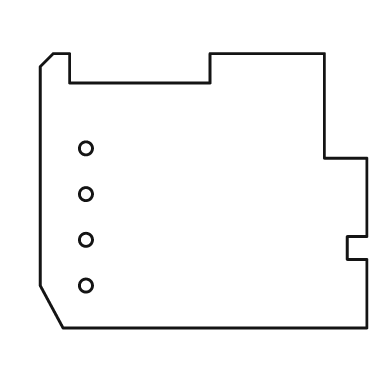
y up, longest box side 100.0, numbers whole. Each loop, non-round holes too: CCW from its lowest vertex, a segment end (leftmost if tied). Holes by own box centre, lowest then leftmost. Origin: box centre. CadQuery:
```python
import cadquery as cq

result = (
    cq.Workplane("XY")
    .moveTo(-43.0, -42.0)
    .lineTo(50.0, -42.0)
    .lineTo(50.0, -21.0)
    .lineTo(44.0, -21.0)
    .lineTo(44.0, -14.0)
    .lineTo(50.0, -14.0)
    .lineTo(50.0, 10.0)
    .lineTo(37.0, 10.0)
    .lineTo(37.0, 42.0)
    .lineTo(2.0, 42.0)
    .lineTo(2.0, 33.0)
    .lineTo(-41.0, 33.0)
    .lineTo(-41.0, 42.0)
    .lineTo(-46.0, 42.0)
    .lineTo(-50.0, 38.0)
    .lineTo(-50.0, -29.0)
    .close()
    .moveTo(-36.0, -29.0)
    .circle(2.0)
    .moveTo(-36.0, -15.0)
    .circle(2.0)
    .moveTo(-36.0, -1.0)
    .circle(2.0)
    .moveTo(-36.0, 13.0)
    .circle(2.0)
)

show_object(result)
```